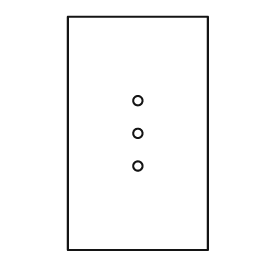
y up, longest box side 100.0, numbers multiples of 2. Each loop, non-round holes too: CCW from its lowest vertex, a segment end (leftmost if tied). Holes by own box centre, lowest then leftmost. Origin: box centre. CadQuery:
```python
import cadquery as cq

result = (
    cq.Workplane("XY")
    .moveTo(-30.0, -50.0)
    .lineTo(30.0, -50.0)
    .lineTo(30.0, 50.0)
    .lineTo(-30.0, 50.0)
    .close()
    .moveTo(0.0, -14.0)
    .circle(2.0)
    .moveTo(0.0, 0.0)
    .circle(2.0)
    .moveTo(0.0, 14.0)
    .circle(2.0)
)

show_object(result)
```